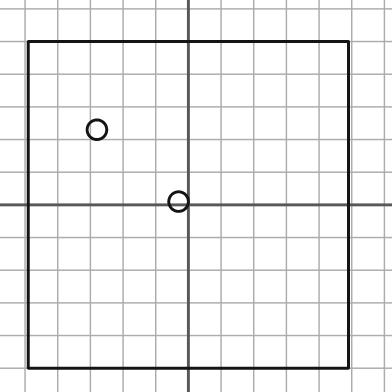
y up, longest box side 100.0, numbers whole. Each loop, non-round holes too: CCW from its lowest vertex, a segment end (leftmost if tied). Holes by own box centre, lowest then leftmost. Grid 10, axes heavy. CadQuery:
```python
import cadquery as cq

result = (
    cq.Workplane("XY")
    .moveTo(-49.0, -50.0)
    .lineTo(49.0, -50.0)
    .lineTo(49.0, 50.0)
    .lineTo(-49.0, 50.0)
    .close()
    .moveTo(-3.0, 1.0)
    .circle(3.0)
    .moveTo(-28.0, 23.0)
    .circle(3.0)
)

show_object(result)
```